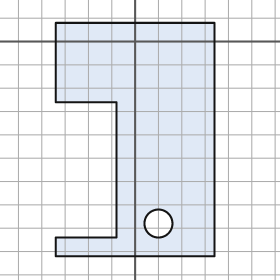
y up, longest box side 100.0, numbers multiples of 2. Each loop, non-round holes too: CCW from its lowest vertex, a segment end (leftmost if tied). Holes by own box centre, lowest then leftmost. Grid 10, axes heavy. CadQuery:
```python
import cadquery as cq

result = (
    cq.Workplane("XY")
    .moveTo(-34.0, -92.0)
    .lineTo(34.0, -92.0)
    .lineTo(34.0, 8.0)
    .lineTo(-34.0, 8.0)
    .lineTo(-34.0, -26.0)
    .lineTo(-8.0, -26.0)
    .lineTo(-8.0, -84.0)
    .lineTo(-34.0, -84.0)
    .close()
    .moveTo(10.0, -78.0)
    .circle(6.0)
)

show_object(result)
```